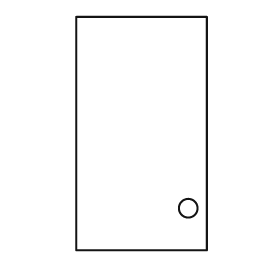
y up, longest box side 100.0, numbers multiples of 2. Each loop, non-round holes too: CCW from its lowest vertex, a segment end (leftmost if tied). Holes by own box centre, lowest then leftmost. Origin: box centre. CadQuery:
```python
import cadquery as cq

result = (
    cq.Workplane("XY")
    .moveTo(-28.0, -50.0)
    .lineTo(28.0, -50.0)
    .lineTo(28.0, 50.0)
    .lineTo(-28.0, 50.0)
    .close()
    .moveTo(20.0, -32.0)
    .circle(4.0)
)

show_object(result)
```